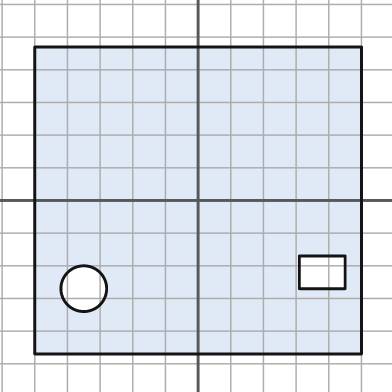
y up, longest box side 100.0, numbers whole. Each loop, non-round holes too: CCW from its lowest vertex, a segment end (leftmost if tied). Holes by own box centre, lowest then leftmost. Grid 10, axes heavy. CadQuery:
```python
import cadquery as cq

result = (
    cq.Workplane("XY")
    .moveTo(-50.0, -47.0)
    .lineTo(50.0, -47.0)
    .lineTo(50.0, 47.0)
    .lineTo(-50.0, 47.0)
    .close()
    .moveTo(-35.0, -27.0)
    .circle(7.0)
    .moveTo(31.0, -27.0)
    .lineTo(45.0, -27.0)
    .lineTo(45.0, -17.0)
    .lineTo(31.0, -17.0)
    .close()
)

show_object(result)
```